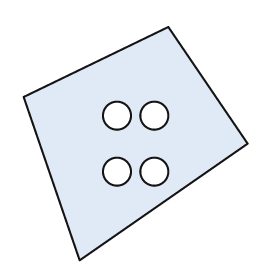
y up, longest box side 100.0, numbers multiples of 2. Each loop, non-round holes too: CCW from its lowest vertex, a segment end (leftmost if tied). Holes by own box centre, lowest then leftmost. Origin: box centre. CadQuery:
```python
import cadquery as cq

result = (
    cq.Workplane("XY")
    .moveTo(-24.0, -50.0)
    .lineTo(48.0, 0.0)
    .lineTo(14.0, 50.0)
    .lineTo(-48.0, 20.0)
    .close()
    .moveTo(-8.0, -12.0)
    .circle(6.0)
    .moveTo(8.0, -12.0)
    .circle(6.0)
    .moveTo(-8.0, 12.0)
    .circle(6.0)
    .moveTo(8.0, 12.0)
    .circle(6.0)
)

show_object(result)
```